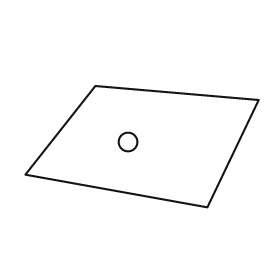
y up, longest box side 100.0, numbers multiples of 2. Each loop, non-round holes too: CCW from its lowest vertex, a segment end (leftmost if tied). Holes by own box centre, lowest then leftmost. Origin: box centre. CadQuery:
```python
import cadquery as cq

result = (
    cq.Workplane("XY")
    .moveTo(28.0, -26.0)
    .lineTo(50.0, 20.0)
    .lineTo(-20.0, 26.0)
    .lineTo(-50.0, -12.0)
    .close()
    .moveTo(-6.0, 2.0)
    .circle(4.0)
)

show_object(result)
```